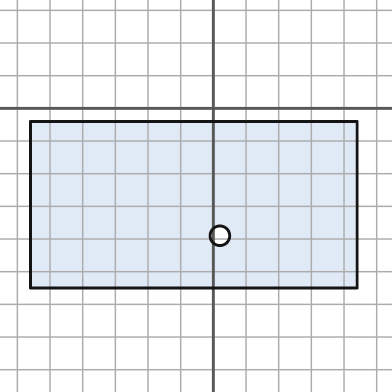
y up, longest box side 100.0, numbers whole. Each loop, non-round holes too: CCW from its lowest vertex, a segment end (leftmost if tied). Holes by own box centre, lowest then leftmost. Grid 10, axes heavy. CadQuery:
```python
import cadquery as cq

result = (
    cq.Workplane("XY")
    .moveTo(-56.0, -55.0)
    .lineTo(44.0, -55.0)
    .lineTo(44.0, -4.0)
    .lineTo(-56.0, -4.0)
    .close()
    .moveTo(2.0, -39.0)
    .circle(3.0)
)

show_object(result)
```